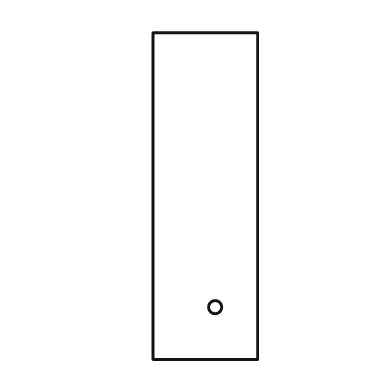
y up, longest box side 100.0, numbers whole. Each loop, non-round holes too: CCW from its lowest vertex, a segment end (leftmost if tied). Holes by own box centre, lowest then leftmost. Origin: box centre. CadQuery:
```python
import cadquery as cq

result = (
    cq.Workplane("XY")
    .moveTo(-16.0, -50.0)
    .lineTo(16.0, -50.0)
    .lineTo(16.0, 50.0)
    .lineTo(-16.0, 50.0)
    .close()
    .moveTo(3.0, -34.0)
    .circle(2.0)
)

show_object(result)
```